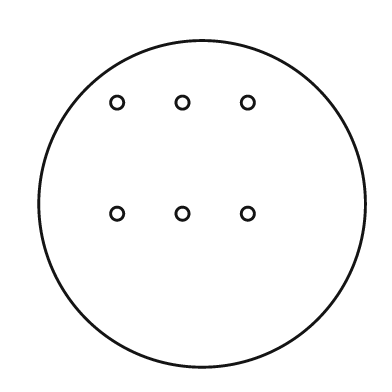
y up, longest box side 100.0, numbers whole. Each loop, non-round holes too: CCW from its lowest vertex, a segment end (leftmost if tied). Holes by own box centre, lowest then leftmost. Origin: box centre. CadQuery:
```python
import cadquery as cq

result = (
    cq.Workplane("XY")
    .moveTo(0.0, 0.0)
    .circle(50.0)
    .moveTo(-26.0, -3.0)
    .circle(2.0)
    .moveTo(-6.0, -3.0)
    .circle(2.0)
    .moveTo(14.0, -3.0)
    .circle(2.0)
    .moveTo(-26.0, 31.0)
    .circle(2.0)
    .moveTo(-6.0, 31.0)
    .circle(2.0)
    .moveTo(14.0, 31.0)
    .circle(2.0)
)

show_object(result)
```